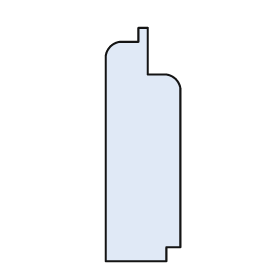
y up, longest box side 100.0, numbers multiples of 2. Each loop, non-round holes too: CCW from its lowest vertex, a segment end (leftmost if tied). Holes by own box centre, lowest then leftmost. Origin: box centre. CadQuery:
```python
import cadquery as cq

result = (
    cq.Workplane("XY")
    .moveTo(-16.0, -50.0)
    .lineTo(10.0, -50.0)
    .lineTo(10.0, -44.0)
    .lineTo(16.0, -44.0)
    .lineTo(16.0, 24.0)
    .threePointArc((14.0, 28.0), (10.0, 30.0))
    .lineTo(2.0, 30.0)
    .lineTo(2.0, 50.0)
    .lineTo(-2.0, 50.0)
    .lineTo(-2.0, 44.0)
    .lineTo(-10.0, 44.0)
    .threePointArc((-14.0, 42.0), (-16.0, 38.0))
    .close()
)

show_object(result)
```